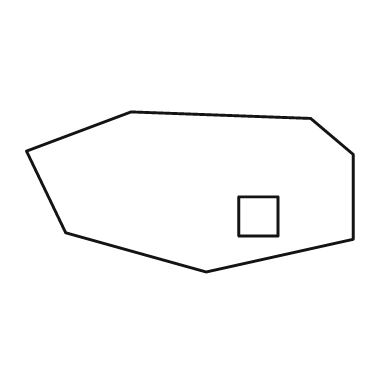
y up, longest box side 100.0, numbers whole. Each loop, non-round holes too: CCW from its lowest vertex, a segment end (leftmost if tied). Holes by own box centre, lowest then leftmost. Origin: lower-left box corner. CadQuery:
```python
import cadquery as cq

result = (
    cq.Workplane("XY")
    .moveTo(55.0, 0.0)
    .lineTo(100.0, 10.0)
    .lineTo(100.0, 36.0)
    .lineTo(87.0, 47.0)
    .lineTo(32.0, 49.0)
    .lineTo(0.0, 37.0)
    .lineTo(12.0, 12.0)
    .close()
    .moveTo(65.0, 11.0)
    .lineTo(77.0, 11.0)
    .lineTo(77.0, 23.0)
    .lineTo(65.0, 23.0)
    .close()
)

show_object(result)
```